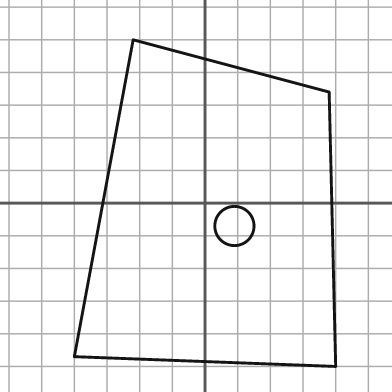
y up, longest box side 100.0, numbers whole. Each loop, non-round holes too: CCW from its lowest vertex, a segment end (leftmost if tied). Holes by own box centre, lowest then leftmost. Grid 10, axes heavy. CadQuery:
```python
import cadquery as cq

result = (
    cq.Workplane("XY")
    .moveTo(40.0, -50.0)
    .lineTo(38.0, 34.0)
    .lineTo(-22.0, 50.0)
    .lineTo(-40.0, -47.0)
    .close()
    .moveTo(9.0, -7.0)
    .circle(6.0)
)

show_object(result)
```